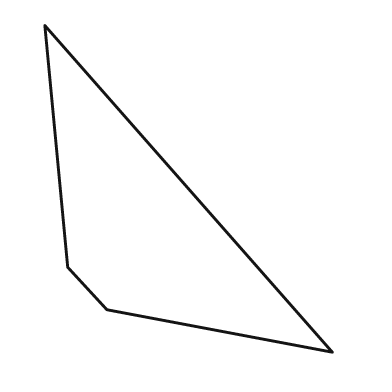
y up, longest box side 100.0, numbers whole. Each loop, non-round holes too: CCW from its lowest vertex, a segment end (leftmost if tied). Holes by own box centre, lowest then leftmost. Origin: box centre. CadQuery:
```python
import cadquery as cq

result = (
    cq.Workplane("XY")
    .moveTo(44.0, -50.0)
    .lineTo(-44.0, 50.0)
    .lineTo(-37.0, -24.0)
    .lineTo(-25.0, -37.0)
    .close()
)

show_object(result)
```